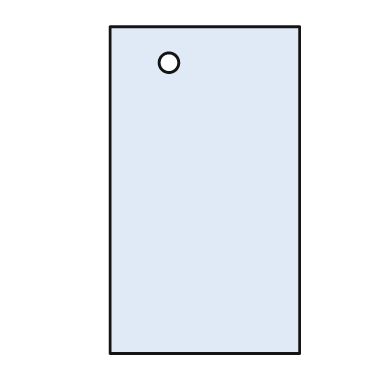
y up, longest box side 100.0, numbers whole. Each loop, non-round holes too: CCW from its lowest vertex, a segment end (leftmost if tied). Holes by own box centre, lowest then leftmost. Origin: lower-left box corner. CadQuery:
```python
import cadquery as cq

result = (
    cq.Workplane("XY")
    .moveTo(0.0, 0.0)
    .lineTo(58.0, 0.0)
    .lineTo(58.0, 100.0)
    .lineTo(0.0, 100.0)
    .close()
    .moveTo(18.0, 89.0)
    .circle(3.0)
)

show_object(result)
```